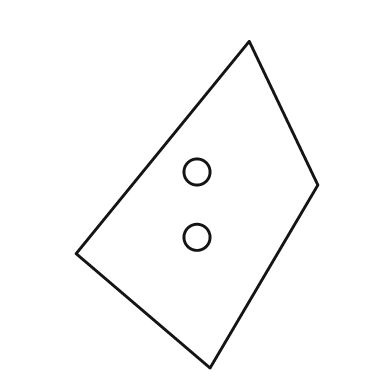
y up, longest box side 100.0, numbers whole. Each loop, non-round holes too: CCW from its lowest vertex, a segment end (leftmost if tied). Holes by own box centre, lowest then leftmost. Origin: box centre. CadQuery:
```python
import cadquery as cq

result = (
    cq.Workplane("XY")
    .moveTo(4.0, -50.0)
    .lineTo(37.0, 6.0)
    .lineTo(16.0, 50.0)
    .lineTo(-37.0, -15.0)
    .close()
    .moveTo(0.0, -10.0)
    .circle(4.0)
    .moveTo(0.0, 10.0)
    .circle(4.0)
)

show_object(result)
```